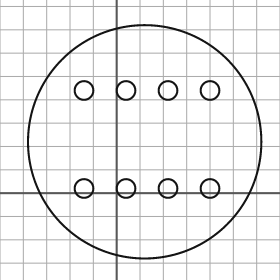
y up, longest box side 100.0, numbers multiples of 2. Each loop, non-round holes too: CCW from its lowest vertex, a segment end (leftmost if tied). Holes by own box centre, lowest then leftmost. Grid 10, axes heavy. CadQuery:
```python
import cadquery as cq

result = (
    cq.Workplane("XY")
    .moveTo(12.0, 22.0)
    .circle(50.0)
    .moveTo(-14.0, 2.0)
    .circle(4.0)
    .moveTo(4.0, 2.0)
    .circle(4.0)
    .moveTo(22.0, 2.0)
    .circle(4.0)
    .moveTo(40.0, 2.0)
    .circle(4.0)
    .moveTo(-14.0, 44.0)
    .circle(4.0)
    .moveTo(4.0, 44.0)
    .circle(4.0)
    .moveTo(22.0, 44.0)
    .circle(4.0)
    .moveTo(40.0, 44.0)
    .circle(4.0)
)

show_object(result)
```